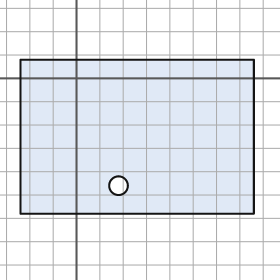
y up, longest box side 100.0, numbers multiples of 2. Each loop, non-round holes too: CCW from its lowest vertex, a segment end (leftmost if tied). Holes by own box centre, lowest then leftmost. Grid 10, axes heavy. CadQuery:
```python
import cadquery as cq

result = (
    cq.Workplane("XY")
    .moveTo(-24.0, -58.0)
    .lineTo(76.0, -58.0)
    .lineTo(76.0, 8.0)
    .lineTo(-24.0, 8.0)
    .close()
    .moveTo(18.0, -46.0)
    .circle(4.0)
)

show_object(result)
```